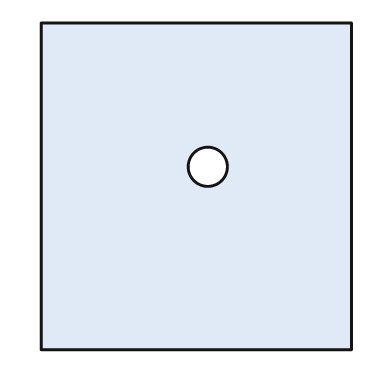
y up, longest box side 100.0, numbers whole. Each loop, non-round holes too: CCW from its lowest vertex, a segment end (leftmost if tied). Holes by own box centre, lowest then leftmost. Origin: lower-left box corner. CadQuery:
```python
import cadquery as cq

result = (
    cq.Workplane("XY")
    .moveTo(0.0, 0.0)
    .lineTo(95.0, 0.0)
    .lineTo(95.0, 100.0)
    .lineTo(0.0, 100.0)
    .close()
    .moveTo(51.0, 56.0)
    .circle(6.0)
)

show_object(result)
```